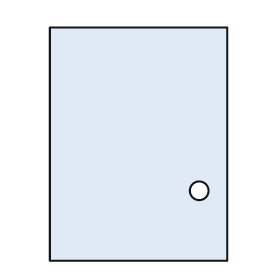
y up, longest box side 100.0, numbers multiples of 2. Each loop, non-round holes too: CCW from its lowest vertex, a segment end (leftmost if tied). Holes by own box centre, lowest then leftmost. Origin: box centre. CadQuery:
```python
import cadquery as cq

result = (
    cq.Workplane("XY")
    .moveTo(-38.0, -50.0)
    .lineTo(38.0, -50.0)
    .lineTo(38.0, 50.0)
    .lineTo(-38.0, 50.0)
    .close()
    .moveTo(26.0, -20.0)
    .circle(4.0)
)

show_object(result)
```